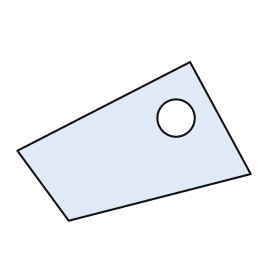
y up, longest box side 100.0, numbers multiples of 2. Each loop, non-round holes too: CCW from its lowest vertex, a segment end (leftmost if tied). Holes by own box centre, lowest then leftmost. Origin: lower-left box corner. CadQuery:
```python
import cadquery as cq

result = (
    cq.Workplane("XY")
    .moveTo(22.0, 0.0)
    .lineTo(100.0, 20.0)
    .lineTo(74.0, 68.0)
    .lineTo(0.0, 30.0)
    .close()
    .moveTo(68.0, 44.0)
    .circle(8.0)
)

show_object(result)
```